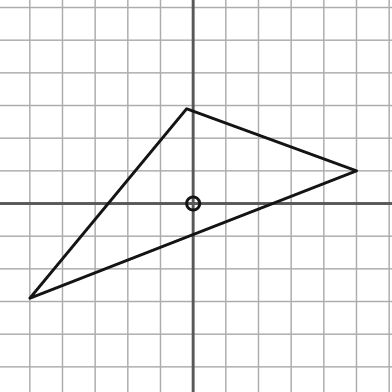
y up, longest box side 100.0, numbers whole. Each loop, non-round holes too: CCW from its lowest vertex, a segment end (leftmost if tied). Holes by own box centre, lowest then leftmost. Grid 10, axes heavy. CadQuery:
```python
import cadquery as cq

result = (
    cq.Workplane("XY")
    .moveTo(-50.0, -29.0)
    .lineTo(50.0, 10.0)
    .lineTo(-2.0, 29.0)
    .close()
    .moveTo(0.0, 0.0)
    .circle(2.0)
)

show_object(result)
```